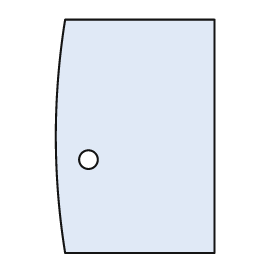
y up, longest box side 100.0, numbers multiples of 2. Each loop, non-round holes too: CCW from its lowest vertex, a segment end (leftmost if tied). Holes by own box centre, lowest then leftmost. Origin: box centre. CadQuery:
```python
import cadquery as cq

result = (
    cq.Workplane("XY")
    .moveTo(-30.0, -50.0)
    .lineTo(34.0, -50.0)
    .lineTo(34.0, 50.0)
    .lineTo(-30.0, 50.0)
    .threePointArc((-34.0, 0.0), (-30.0, -50.0))
    .close()
    .moveTo(-20.0, -10.0)
    .circle(4.0)
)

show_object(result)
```